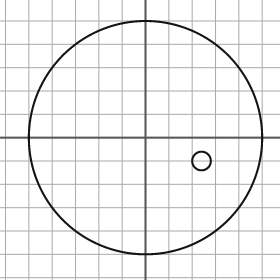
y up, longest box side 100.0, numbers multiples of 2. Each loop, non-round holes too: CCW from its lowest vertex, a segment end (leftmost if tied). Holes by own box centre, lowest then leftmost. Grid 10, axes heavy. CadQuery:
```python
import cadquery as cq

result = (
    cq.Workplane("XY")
    .moveTo(0.0, 0.0)
    .circle(50.0)
    .moveTo(24.0, -10.0)
    .circle(4.0)
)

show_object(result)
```